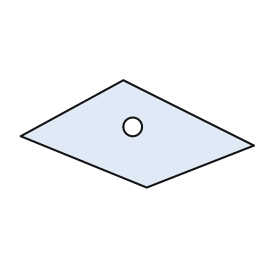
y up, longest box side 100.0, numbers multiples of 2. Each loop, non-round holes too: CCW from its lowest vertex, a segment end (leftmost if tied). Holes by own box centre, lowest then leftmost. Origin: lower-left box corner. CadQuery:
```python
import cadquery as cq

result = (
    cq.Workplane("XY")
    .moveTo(54.0, 0.0)
    .lineTo(100.0, 18.0)
    .lineTo(44.0, 46.0)
    .lineTo(0.0, 22.0)
    .close()
    .moveTo(48.0, 26.0)
    .circle(4.0)
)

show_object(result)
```